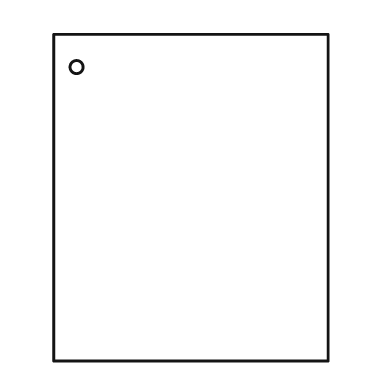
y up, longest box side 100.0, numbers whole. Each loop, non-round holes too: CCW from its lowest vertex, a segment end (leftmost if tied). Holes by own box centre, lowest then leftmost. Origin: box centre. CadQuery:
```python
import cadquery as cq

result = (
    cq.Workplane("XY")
    .moveTo(-42.0, -50.0)
    .lineTo(42.0, -50.0)
    .lineTo(42.0, 50.0)
    .lineTo(-42.0, 50.0)
    .close()
    .moveTo(-35.0, 40.0)
    .circle(2.0)
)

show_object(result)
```